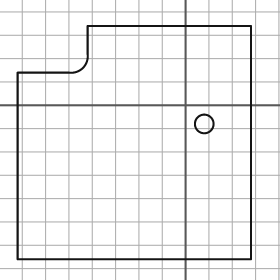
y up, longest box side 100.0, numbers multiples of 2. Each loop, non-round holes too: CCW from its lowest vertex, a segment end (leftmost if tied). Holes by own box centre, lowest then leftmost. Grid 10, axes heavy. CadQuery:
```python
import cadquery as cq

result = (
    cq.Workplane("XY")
    .moveTo(-72.0, -66.0)
    .lineTo(28.0, -66.0)
    .lineTo(28.0, 34.0)
    .lineTo(-42.0, 34.0)
    .lineTo(-42.0, 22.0)
    .threePointArc((-44.0, 16.0), (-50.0, 14.0))
    .lineTo(-72.0, 14.0)
    .close()
    .moveTo(8.0, -8.0)
    .circle(4.0)
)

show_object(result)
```